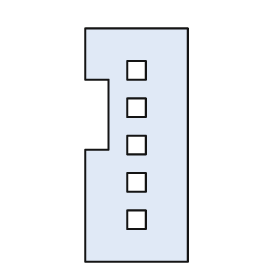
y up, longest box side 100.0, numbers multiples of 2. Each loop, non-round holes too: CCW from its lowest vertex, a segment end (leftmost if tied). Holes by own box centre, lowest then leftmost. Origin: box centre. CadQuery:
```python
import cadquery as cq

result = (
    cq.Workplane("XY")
    .moveTo(-22.0, -50.0)
    .lineTo(22.0, -50.0)
    .lineTo(22.0, 50.0)
    .lineTo(-22.0, 50.0)
    .lineTo(-22.0, 28.0)
    .lineTo(-12.0, 28.0)
    .lineTo(-12.0, -2.0)
    .lineTo(-22.0, -2.0)
    .close()
    .moveTo(-4.0, -36.0)
    .lineTo(4.0, -36.0)
    .lineTo(4.0, -28.0)
    .lineTo(-4.0, -28.0)
    .close()
    .moveTo(-4.0, -20.0)
    .lineTo(4.0, -20.0)
    .lineTo(4.0, -12.0)
    .lineTo(-4.0, -12.0)
    .close()
    .moveTo(-4.0, -4.0)
    .lineTo(4.0, -4.0)
    .lineTo(4.0, 4.0)
    .lineTo(-4.0, 4.0)
    .close()
    .moveTo(-4.0, 12.0)
    .lineTo(4.0, 12.0)
    .lineTo(4.0, 20.0)
    .lineTo(-4.0, 20.0)
    .close()
    .moveTo(-4.0, 28.0)
    .lineTo(4.0, 28.0)
    .lineTo(4.0, 36.0)
    .lineTo(-4.0, 36.0)
    .close()
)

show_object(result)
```